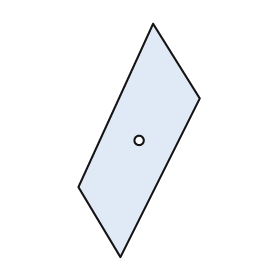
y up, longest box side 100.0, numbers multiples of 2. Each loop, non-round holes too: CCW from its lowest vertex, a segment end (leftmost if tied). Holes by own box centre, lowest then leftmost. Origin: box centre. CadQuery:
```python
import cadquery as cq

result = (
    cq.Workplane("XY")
    .moveTo(-8.0, -50.0)
    .lineTo(26.0, 18.0)
    .lineTo(6.0, 50.0)
    .lineTo(-26.0, -20.0)
    .close()
    .moveTo(0.0, 0.0)
    .circle(2.0)
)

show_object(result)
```